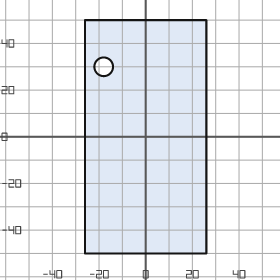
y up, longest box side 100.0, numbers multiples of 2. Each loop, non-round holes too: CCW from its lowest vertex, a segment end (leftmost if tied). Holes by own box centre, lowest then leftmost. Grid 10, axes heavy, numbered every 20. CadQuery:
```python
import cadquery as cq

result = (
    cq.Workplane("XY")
    .moveTo(-26.0, -50.0)
    .lineTo(26.0, -50.0)
    .lineTo(26.0, 50.0)
    .lineTo(-26.0, 50.0)
    .close()
    .moveTo(-18.0, 30.0)
    .circle(4.0)
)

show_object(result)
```